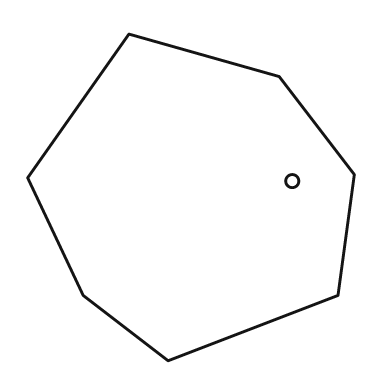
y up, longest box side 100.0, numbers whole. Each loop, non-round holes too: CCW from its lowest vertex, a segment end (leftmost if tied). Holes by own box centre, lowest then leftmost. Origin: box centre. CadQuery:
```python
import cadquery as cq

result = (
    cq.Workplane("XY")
    .moveTo(-7.0, -50.0)
    .lineTo(45.0, -30.0)
    .lineTo(50.0, 7.0)
    .lineTo(27.0, 37.0)
    .lineTo(-19.0, 50.0)
    .lineTo(-50.0, 6.0)
    .lineTo(-33.0, -30.0)
    .close()
    .moveTo(31.0, 5.0)
    .circle(2.0)
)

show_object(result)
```